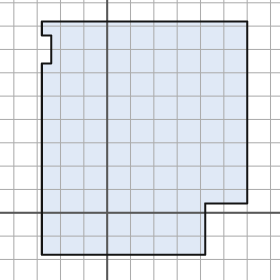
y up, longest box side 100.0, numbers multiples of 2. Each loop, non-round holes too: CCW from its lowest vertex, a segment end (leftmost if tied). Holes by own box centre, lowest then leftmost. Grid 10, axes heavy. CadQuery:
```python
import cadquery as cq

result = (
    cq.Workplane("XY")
    .moveTo(-28.0, -18.0)
    .lineTo(42.0, -18.0)
    .lineTo(42.0, 4.0)
    .lineTo(60.0, 4.0)
    .lineTo(60.0, 82.0)
    .lineTo(-28.0, 82.0)
    .lineTo(-28.0, 76.0)
    .lineTo(-24.0, 76.0)
    .lineTo(-24.0, 64.0)
    .lineTo(-28.0, 64.0)
    .close()
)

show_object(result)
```